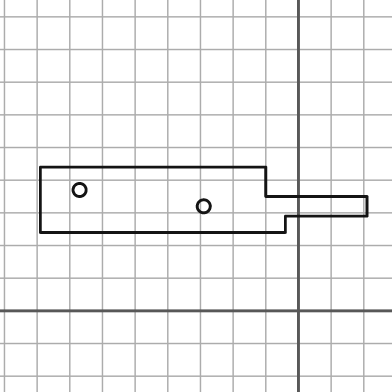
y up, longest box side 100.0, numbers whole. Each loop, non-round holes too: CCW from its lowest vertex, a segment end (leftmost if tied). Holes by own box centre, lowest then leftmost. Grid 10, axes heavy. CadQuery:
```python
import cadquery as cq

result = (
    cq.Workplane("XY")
    .moveTo(-79.0, 24.0)
    .lineTo(-4.0, 24.0)
    .lineTo(-4.0, 29.0)
    .lineTo(21.0, 29.0)
    .lineTo(21.0, 35.0)
    .lineTo(-10.0, 35.0)
    .lineTo(-10.0, 44.0)
    .lineTo(-79.0, 44.0)
    .close()
    .moveTo(-29.0, 32.0)
    .circle(2.0)
    .moveTo(-67.0, 37.0)
    .circle(2.0)
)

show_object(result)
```